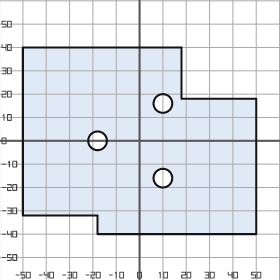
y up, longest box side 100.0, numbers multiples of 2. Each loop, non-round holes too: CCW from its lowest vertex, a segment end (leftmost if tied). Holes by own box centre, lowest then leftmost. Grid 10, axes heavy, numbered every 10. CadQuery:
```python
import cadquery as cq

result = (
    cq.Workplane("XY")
    .moveTo(-18.0, -40.0)
    .lineTo(50.0, -40.0)
    .lineTo(50.0, 18.0)
    .lineTo(18.0, 18.0)
    .lineTo(18.0, 40.0)
    .lineTo(-50.0, 40.0)
    .lineTo(-50.0, -32.0)
    .lineTo(-18.0, -32.0)
    .close()
    .moveTo(10.0, -16.0)
    .circle(4.0)
    .moveTo(-18.0, 0.0)
    .circle(4.0)
    .moveTo(10.0, 16.0)
    .circle(4.0)
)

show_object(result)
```